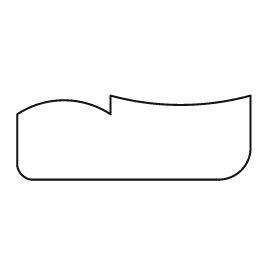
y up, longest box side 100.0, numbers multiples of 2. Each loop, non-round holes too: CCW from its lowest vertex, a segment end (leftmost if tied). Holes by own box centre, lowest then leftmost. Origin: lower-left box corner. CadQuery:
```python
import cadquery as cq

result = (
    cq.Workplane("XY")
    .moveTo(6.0, 0.0)
    .lineTo(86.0, 0.0)
    .threePointArc((96.0, 4.0), (100.0, 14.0))
    .lineTo(100.0, 36.0)
    .threePointArc((70.0, 32.0), (40.0, 36.0))
    .lineTo(40.0, 28.0)
    .threePointArc((20.0, 34.0), (0.0, 28.0))
    .lineTo(0.0, 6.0)
    .threePointArc((2.0, 2.0), (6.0, 0.0))
    .close()
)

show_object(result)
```